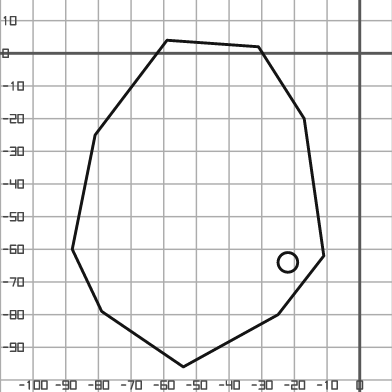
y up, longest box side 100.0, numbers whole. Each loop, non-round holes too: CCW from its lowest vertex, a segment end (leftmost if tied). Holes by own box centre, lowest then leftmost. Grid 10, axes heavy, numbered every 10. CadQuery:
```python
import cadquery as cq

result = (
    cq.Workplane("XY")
    .moveTo(-54.0, -96.0)
    .lineTo(-25.0, -80.0)
    .lineTo(-11.0, -62.0)
    .lineTo(-17.0, -20.0)
    .lineTo(-31.0, 2.0)
    .lineTo(-59.0, 4.0)
    .lineTo(-81.0, -25.0)
    .lineTo(-88.0, -60.0)
    .lineTo(-79.0, -79.0)
    .close()
    .moveTo(-22.0, -64.0)
    .circle(3.0)
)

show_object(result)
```